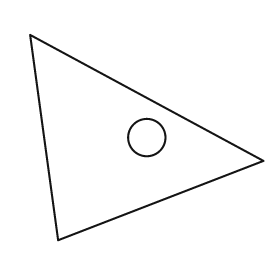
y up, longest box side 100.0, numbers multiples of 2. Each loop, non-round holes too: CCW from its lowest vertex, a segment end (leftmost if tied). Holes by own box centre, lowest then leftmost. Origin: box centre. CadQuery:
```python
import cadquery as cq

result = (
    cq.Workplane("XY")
    .moveTo(-38.0, -44.0)
    .lineTo(50.0, -10.0)
    .lineTo(-50.0, 44.0)
    .close()
    .moveTo(0.0, 0.0)
    .circle(8.0)
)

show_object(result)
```